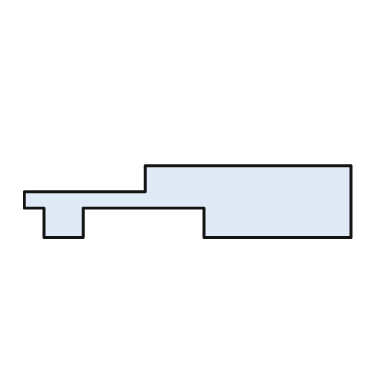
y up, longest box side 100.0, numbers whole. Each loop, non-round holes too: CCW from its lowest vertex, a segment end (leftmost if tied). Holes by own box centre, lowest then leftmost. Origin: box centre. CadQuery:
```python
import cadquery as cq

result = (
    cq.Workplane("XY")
    .moveTo(-44.0, -11.0)
    .lineTo(-32.0, -11.0)
    .lineTo(-32.0, -2.0)
    .lineTo(5.0, -2.0)
    .lineTo(5.0, -11.0)
    .lineTo(50.0, -11.0)
    .lineTo(50.0, 11.0)
    .lineTo(-13.0, 11.0)
    .lineTo(-13.0, 3.0)
    .lineTo(-50.0, 3.0)
    .lineTo(-50.0, -2.0)
    .lineTo(-44.0, -2.0)
    .close()
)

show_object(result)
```